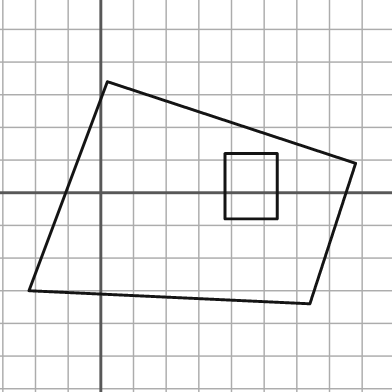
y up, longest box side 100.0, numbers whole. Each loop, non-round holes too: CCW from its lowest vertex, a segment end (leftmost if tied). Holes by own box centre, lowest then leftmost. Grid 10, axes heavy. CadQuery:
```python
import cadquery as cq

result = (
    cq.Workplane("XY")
    .moveTo(64.0, -34.0)
    .lineTo(78.0, 9.0)
    .lineTo(2.0, 34.0)
    .lineTo(-22.0, -30.0)
    .close()
    .moveTo(38.0, -8.0)
    .lineTo(54.0, -8.0)
    .lineTo(54.0, 12.0)
    .lineTo(38.0, 12.0)
    .close()
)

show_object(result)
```